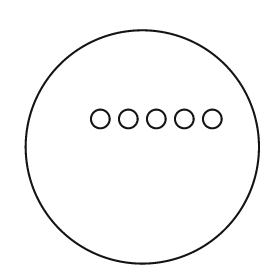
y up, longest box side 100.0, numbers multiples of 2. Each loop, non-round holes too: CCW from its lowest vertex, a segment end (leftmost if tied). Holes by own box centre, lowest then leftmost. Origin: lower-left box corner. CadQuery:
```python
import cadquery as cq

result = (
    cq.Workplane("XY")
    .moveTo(50.0, 50.0)
    .circle(50.0)
    .moveTo(32.0, 62.0)
    .circle(4.0)
    .moveTo(44.0, 62.0)
    .circle(4.0)
    .moveTo(56.0, 62.0)
    .circle(4.0)
    .moveTo(68.0, 62.0)
    .circle(4.0)
    .moveTo(80.0, 62.0)
    .circle(4.0)
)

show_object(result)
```